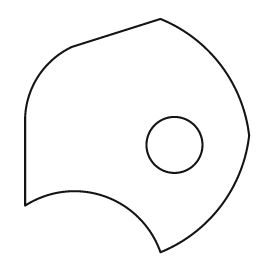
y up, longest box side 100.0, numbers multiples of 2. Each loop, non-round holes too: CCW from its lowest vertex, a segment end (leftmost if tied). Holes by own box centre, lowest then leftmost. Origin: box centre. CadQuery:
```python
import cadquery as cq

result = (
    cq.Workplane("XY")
    .moveTo(10.0, -50.0)
    .threePointArc((36.0, -30.0), (48.0, 0.0))
    .threePointArc((36.0, 30.0), (10.0, 50.0))
    .lineTo(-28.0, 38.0)
    .threePointArc((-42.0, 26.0), (-48.0, 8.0))
    .lineTo(-48.0, -30.0)
    .threePointArc((-14.0, -26.0), (10.0, -50.0))
    .close()
    .moveTo(16.0, -4.0)
    .circle(12.0)
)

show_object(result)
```